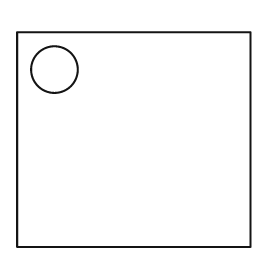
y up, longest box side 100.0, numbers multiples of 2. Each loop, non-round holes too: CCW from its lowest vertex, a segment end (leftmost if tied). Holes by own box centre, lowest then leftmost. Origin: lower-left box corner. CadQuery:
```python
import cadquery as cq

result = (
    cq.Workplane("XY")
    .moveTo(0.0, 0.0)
    .lineTo(100.0, 0.0)
    .lineTo(100.0, 92.0)
    .lineTo(0.0, 92.0)
    .close()
    .moveTo(16.0, 76.0)
    .circle(10.0)
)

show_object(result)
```